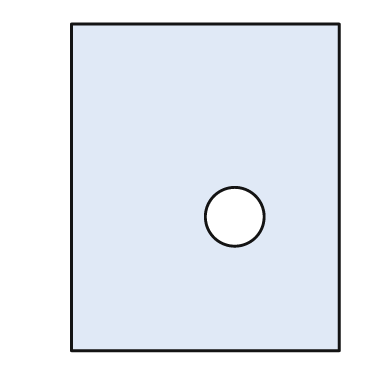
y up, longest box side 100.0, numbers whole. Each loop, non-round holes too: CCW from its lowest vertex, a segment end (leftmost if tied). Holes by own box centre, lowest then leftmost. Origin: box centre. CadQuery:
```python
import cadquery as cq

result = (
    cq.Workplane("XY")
    .moveTo(-41.0, -50.0)
    .lineTo(41.0, -50.0)
    .lineTo(41.0, 50.0)
    .lineTo(-41.0, 50.0)
    .close()
    .moveTo(9.0, -9.0)
    .circle(9.0)
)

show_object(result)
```